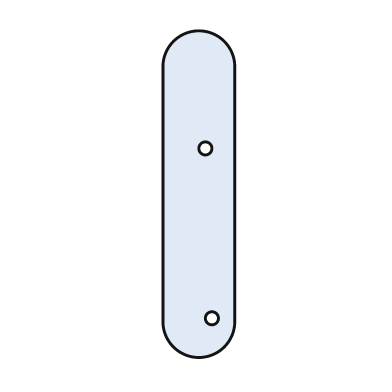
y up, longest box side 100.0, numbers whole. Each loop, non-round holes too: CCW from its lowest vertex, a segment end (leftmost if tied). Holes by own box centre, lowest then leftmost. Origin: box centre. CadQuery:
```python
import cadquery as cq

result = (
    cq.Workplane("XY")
    .moveTo(-11.0, -39.0)
    .threePointArc((0.0, -50.0), (11.0, -39.0))
    .lineTo(11.0, 39.0)
    .threePointArc((0.0, 50.0), (-11.0, 39.0))
    .close()
    .moveTo(4.0, -38.0)
    .circle(2.0)
    .moveTo(2.0, 14.0)
    .circle(2.0)
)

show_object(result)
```